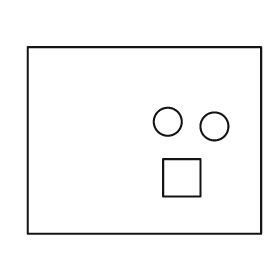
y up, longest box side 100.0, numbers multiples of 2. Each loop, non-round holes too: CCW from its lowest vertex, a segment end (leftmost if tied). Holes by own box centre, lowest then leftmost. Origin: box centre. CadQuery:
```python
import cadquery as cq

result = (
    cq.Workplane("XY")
    .moveTo(-50.0, -40.0)
    .lineTo(50.0, -40.0)
    .lineTo(50.0, 40.0)
    .lineTo(-50.0, 40.0)
    .close()
    .moveTo(8.0, -24.0)
    .lineTo(24.0, -24.0)
    .lineTo(24.0, -8.0)
    .lineTo(8.0, -8.0)
    .close()
    .moveTo(30.0, 6.0)
    .circle(6.0)
    .moveTo(10.0, 8.0)
    .circle(6.0)
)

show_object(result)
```